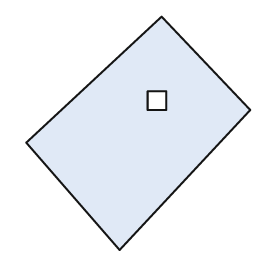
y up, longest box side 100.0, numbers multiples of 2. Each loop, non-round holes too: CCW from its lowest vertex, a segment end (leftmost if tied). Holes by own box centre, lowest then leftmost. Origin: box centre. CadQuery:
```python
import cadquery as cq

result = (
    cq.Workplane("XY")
    .moveTo(-8.0, -50.0)
    .lineTo(48.0, 10.0)
    .lineTo(10.0, 50.0)
    .lineTo(-48.0, -4.0)
    .close()
    .moveTo(4.0, 10.0)
    .lineTo(12.0, 10.0)
    .lineTo(12.0, 18.0)
    .lineTo(4.0, 18.0)
    .close()
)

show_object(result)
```